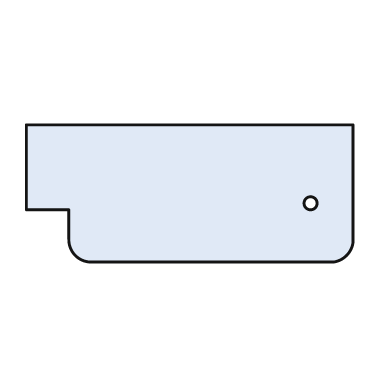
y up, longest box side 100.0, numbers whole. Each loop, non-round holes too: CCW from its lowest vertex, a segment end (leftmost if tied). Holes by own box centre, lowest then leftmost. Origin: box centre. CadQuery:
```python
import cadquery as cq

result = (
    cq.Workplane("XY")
    .moveTo(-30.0, -21.0)
    .lineTo(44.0, -21.0)
    .threePointArc((48.0, -19.0), (50.0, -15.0))
    .lineTo(50.0, 21.0)
    .lineTo(-50.0, 21.0)
    .lineTo(-50.0, -5.0)
    .lineTo(-37.0, -5.0)
    .lineTo(-37.0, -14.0)
    .threePointArc((-35.0, -19.0), (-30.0, -21.0))
    .close()
    .moveTo(37.0, -3.0)
    .circle(2.0)
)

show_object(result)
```